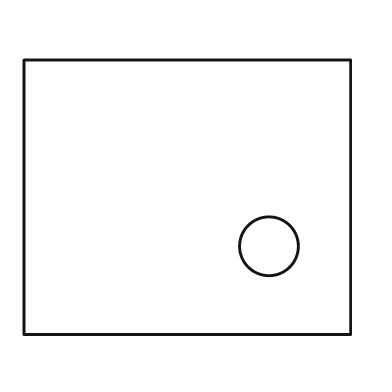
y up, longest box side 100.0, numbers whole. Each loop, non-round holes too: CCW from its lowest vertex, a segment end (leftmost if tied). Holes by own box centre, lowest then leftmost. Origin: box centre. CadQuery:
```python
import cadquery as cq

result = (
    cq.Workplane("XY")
    .moveTo(-50.0, -42.0)
    .lineTo(50.0, -42.0)
    .lineTo(50.0, 42.0)
    .lineTo(-50.0, 42.0)
    .close()
    .moveTo(25.0, -15.0)
    .circle(9.0)
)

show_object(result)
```